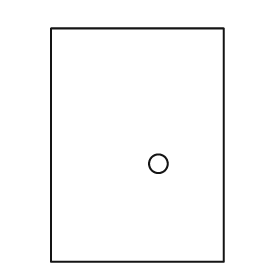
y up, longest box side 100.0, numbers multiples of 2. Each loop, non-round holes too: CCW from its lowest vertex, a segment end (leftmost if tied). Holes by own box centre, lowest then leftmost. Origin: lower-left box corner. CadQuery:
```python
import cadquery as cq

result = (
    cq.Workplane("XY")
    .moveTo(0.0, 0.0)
    .lineTo(74.0, 0.0)
    .lineTo(74.0, 100.0)
    .lineTo(0.0, 100.0)
    .close()
    .moveTo(46.0, 42.0)
    .circle(4.0)
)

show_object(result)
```